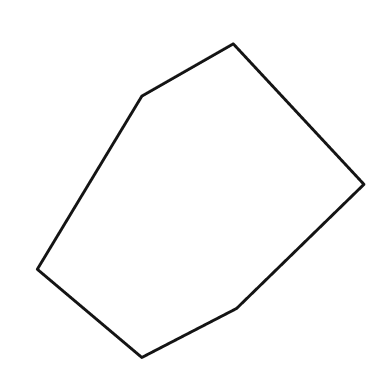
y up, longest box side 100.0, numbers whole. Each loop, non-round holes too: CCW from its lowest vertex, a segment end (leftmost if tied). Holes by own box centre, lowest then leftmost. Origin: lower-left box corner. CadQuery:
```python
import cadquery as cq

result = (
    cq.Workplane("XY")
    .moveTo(32.0, 0.0)
    .lineTo(61.0, 15.0)
    .lineTo(100.0, 53.0)
    .lineTo(60.0, 96.0)
    .lineTo(32.0, 80.0)
    .lineTo(0.0, 27.0)
    .close()
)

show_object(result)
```